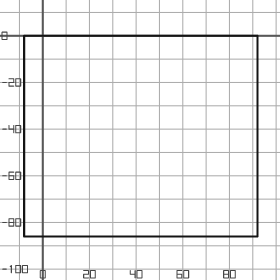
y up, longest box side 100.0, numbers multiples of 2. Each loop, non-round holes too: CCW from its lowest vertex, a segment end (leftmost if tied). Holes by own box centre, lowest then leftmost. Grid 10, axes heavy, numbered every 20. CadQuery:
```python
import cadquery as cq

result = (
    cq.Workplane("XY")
    .moveTo(-8.0, -86.0)
    .lineTo(92.0, -86.0)
    .lineTo(92.0, 0.0)
    .lineTo(-8.0, 0.0)
    .close()
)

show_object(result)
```